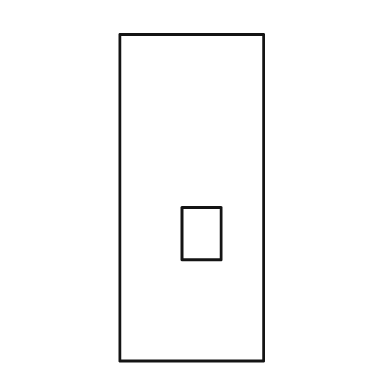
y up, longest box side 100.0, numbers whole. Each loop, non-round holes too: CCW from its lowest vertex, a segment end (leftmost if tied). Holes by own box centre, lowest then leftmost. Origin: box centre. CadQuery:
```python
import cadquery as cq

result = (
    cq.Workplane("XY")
    .moveTo(-22.0, -50.0)
    .lineTo(22.0, -50.0)
    .lineTo(22.0, 50.0)
    .lineTo(-22.0, 50.0)
    .close()
    .moveTo(-3.0, -19.0)
    .lineTo(9.0, -19.0)
    .lineTo(9.0, -3.0)
    .lineTo(-3.0, -3.0)
    .close()
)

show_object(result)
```